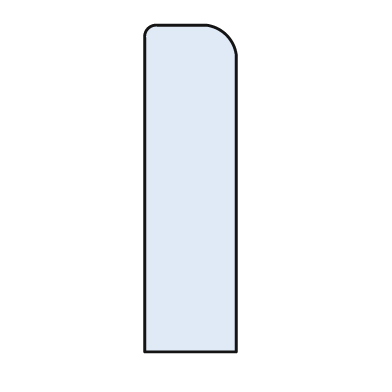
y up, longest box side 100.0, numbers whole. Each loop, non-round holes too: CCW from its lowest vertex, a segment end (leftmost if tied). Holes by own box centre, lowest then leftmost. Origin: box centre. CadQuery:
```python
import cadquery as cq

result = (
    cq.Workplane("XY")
    .moveTo(-14.0, -50.0)
    .lineTo(14.0, -50.0)
    .lineTo(14.0, 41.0)
    .threePointArc((11.0, 47.0), (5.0, 50.0))
    .lineTo(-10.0, 50.0)
    .threePointArc((-13.0, 49.0), (-14.0, 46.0))
    .close()
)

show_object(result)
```